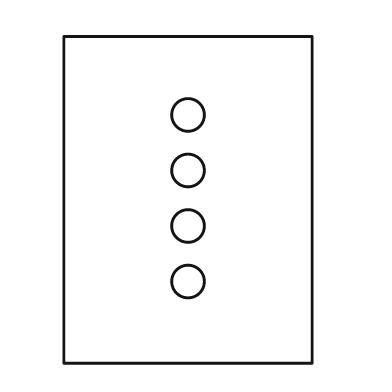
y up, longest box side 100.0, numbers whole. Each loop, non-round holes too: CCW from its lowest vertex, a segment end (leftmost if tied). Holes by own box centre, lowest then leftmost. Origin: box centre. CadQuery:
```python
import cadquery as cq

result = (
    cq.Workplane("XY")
    .moveTo(-38.0, -50.0)
    .lineTo(38.0, -50.0)
    .lineTo(38.0, 50.0)
    .lineTo(-38.0, 50.0)
    .close()
    .moveTo(0.0, -25.0)
    .circle(5.0)
    .moveTo(0.0, -8.0)
    .circle(5.0)
    .moveTo(0.0, 9.0)
    .circle(5.0)
    .moveTo(0.0, 26.0)
    .circle(5.0)
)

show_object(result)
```